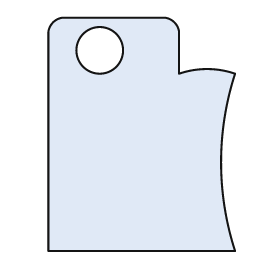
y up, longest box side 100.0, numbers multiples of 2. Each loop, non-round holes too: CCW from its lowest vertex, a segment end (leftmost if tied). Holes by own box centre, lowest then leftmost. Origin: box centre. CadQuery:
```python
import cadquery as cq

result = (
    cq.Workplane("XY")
    .moveTo(-40.0, -50.0)
    .lineTo(40.0, -50.0)
    .threePointArc((34.0, -12.0), (40.0, 26.0))
    .threePointArc((28.0, 28.0), (16.0, 26.0))
    .lineTo(16.0, 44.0)
    .threePointArc((14.0, 48.0), (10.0, 50.0))
    .lineTo(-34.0, 50.0)
    .threePointArc((-38.0, 48.0), (-40.0, 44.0))
    .close()
    .moveTo(-18.0, 36.0)
    .circle(10.0)
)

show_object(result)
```